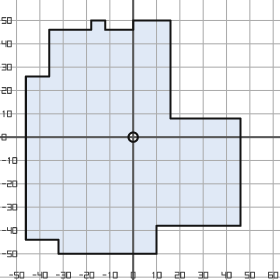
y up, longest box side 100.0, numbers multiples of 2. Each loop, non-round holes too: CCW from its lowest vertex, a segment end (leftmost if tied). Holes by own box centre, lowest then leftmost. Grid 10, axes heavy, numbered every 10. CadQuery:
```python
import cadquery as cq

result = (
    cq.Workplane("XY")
    .moveTo(-32.0, -50.0)
    .lineTo(10.0, -50.0)
    .lineTo(10.0, -38.0)
    .lineTo(46.0, -38.0)
    .lineTo(46.0, 8.0)
    .lineTo(16.0, 8.0)
    .lineTo(16.0, 50.0)
    .lineTo(0.0, 50.0)
    .lineTo(0.0, 46.0)
    .lineTo(-12.0, 46.0)
    .lineTo(-12.0, 50.0)
    .lineTo(-18.0, 50.0)
    .lineTo(-18.0, 46.0)
    .lineTo(-36.0, 46.0)
    .lineTo(-36.0, 26.0)
    .lineTo(-46.0, 26.0)
    .lineTo(-46.0, -44.0)
    .lineTo(-32.0, -44.0)
    .close()
    .moveTo(0.0, 0.0)
    .circle(2.0)
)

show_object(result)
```